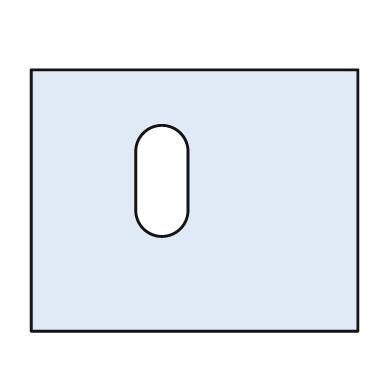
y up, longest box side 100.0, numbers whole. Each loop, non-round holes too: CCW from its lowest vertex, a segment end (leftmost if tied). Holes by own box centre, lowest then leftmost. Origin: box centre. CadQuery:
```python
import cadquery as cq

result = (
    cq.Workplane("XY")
    .moveTo(-50.0, -40.0)
    .lineTo(50.0, -40.0)
    .lineTo(50.0, 40.0)
    .lineTo(-50.0, 40.0)
    .close()
    .moveTo(-18.0, -3.0)
    .threePointArc((-10.0, -11.0), (-2.0, -3.0))
    .lineTo(-2.0, 15.0)
    .threePointArc((-10.0, 23.0), (-18.0, 15.0))
    .close()
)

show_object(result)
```